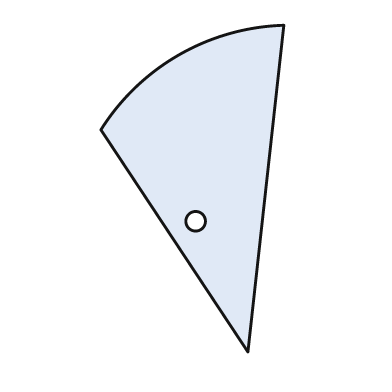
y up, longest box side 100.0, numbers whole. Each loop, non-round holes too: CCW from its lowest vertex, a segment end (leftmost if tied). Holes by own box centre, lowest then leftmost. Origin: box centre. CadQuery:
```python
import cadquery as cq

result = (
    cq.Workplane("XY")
    .moveTo(17.0, -50.0)
    .lineTo(28.0, 50.0)
    .threePointArc((-4.0, 41.0), (-28.0, 18.0))
    .close()
    .moveTo(1.0, -10.0)
    .circle(3.0)
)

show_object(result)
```